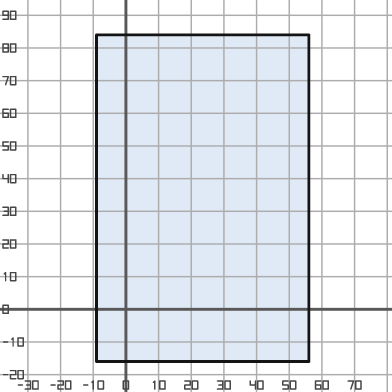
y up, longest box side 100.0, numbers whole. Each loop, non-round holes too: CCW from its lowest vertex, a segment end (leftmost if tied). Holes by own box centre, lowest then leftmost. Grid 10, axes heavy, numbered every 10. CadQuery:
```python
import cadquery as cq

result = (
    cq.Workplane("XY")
    .moveTo(-9.0, -16.0)
    .lineTo(56.0, -16.0)
    .lineTo(56.0, 84.0)
    .lineTo(-9.0, 84.0)
    .close()
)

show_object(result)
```